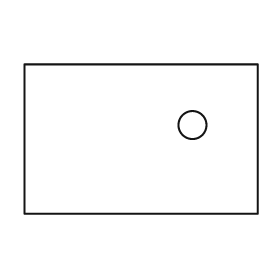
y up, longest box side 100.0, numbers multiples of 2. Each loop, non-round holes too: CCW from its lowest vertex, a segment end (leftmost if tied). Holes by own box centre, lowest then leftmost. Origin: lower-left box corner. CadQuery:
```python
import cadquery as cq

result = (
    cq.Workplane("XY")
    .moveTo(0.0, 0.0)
    .lineTo(100.0, 0.0)
    .lineTo(100.0, 64.0)
    .lineTo(0.0, 64.0)
    .close()
    .moveTo(72.0, 38.0)
    .circle(6.0)
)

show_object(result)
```